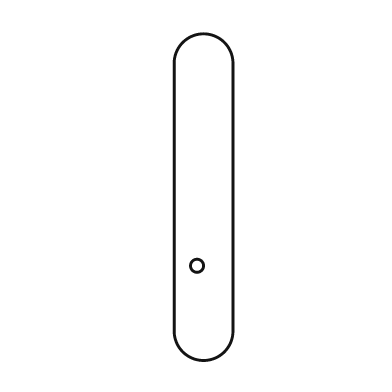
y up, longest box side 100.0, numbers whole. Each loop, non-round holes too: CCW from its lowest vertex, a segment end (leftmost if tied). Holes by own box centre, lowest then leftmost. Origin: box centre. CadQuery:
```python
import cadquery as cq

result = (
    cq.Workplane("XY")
    .moveTo(-9.0, -41.0)
    .threePointArc((0.0, -50.0), (9.0, -41.0))
    .lineTo(9.0, 41.0)
    .threePointArc((0.0, 50.0), (-9.0, 41.0))
    .close()
    .moveTo(-2.0, -21.0)
    .circle(2.0)
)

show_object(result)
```